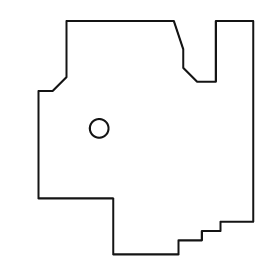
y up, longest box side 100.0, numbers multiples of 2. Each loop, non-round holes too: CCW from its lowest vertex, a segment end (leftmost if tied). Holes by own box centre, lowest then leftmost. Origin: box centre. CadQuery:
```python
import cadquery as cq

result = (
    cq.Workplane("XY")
    .moveTo(-14.0, -50.0)
    .lineTo(14.0, -50.0)
    .lineTo(14.0, -44.0)
    .lineTo(24.0, -44.0)
    .lineTo(24.0, -40.0)
    .lineTo(32.0, -40.0)
    .lineTo(32.0, -36.0)
    .lineTo(46.0, -36.0)
    .lineTo(46.0, 50.0)
    .lineTo(30.0, 50.0)
    .lineTo(30.0, 24.0)
    .lineTo(22.0, 24.0)
    .lineTo(16.0, 30.0)
    .lineTo(16.0, 38.0)
    .lineTo(12.0, 50.0)
    .lineTo(-34.0, 50.0)
    .lineTo(-34.0, 26.0)
    .lineTo(-40.0, 20.0)
    .lineTo(-46.0, 20.0)
    .lineTo(-46.0, -26.0)
    .lineTo(-14.0, -26.0)
    .close()
    .moveTo(-20.0, 4.0)
    .circle(4.0)
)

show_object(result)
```